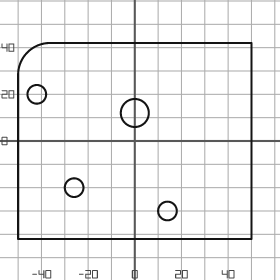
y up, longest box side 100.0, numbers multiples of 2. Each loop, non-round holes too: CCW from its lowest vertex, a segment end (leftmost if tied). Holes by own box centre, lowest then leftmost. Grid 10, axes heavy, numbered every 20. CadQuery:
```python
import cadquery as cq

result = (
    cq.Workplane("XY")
    .moveTo(-50.0, -42.0)
    .lineTo(50.0, -42.0)
    .lineTo(50.0, 42.0)
    .lineTo(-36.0, 42.0)
    .threePointArc((-46.0, 38.0), (-50.0, 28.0))
    .close()
    .moveTo(14.0, -30.0)
    .circle(4.0)
    .moveTo(-26.0, -20.0)
    .circle(4.0)
    .moveTo(0.0, 12.0)
    .circle(6.0)
    .moveTo(-42.0, 20.0)
    .circle(4.0)
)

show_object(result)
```